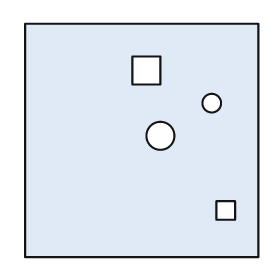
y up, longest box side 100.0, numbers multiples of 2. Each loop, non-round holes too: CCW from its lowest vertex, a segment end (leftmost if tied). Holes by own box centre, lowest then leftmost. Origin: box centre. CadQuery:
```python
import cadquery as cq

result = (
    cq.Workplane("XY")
    .moveTo(-50.0, -50.0)
    .lineTo(50.0, -50.0)
    .lineTo(50.0, 50.0)
    .lineTo(-50.0, 50.0)
    .close()
    .moveTo(32.0, -34.0)
    .lineTo(40.0, -34.0)
    .lineTo(40.0, -26.0)
    .lineTo(32.0, -26.0)
    .close()
    .moveTo(8.0, 2.0)
    .circle(6.0)
    .moveTo(30.0, 16.0)
    .circle(4.0)
    .moveTo(-4.0, 24.0)
    .lineTo(8.0, 24.0)
    .lineTo(8.0, 36.0)
    .lineTo(-4.0, 36.0)
    .close()
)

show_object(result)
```